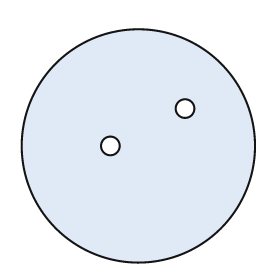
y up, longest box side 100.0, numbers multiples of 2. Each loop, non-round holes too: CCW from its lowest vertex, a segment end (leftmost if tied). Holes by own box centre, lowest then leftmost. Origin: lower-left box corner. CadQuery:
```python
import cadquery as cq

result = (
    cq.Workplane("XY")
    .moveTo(50.0, 50.0)
    .circle(50.0)
    .moveTo(38.0, 50.0)
    .circle(4.0)
    .moveTo(70.0, 66.0)
    .circle(4.0)
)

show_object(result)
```